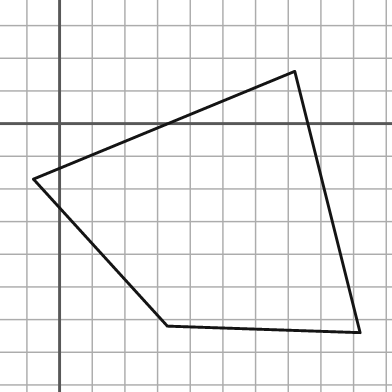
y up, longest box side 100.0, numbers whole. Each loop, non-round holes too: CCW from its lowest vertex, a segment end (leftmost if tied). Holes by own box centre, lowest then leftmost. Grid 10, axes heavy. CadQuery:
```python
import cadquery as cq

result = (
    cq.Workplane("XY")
    .moveTo(92.0, -64.0)
    .lineTo(72.0, 16.0)
    .lineTo(-8.0, -17.0)
    .lineTo(33.0, -62.0)
    .close()
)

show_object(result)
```